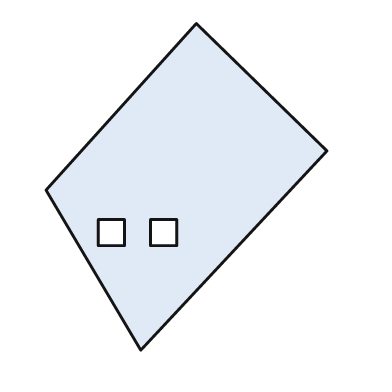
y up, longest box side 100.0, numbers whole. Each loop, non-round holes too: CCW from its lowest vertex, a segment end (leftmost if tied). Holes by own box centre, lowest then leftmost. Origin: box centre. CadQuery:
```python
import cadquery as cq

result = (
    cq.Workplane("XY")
    .moveTo(-14.0, -50.0)
    .lineTo(43.0, 11.0)
    .lineTo(3.0, 50.0)
    .lineTo(-43.0, -1.0)
    .close()
    .moveTo(-27.0, -18.0)
    .lineTo(-19.0, -18.0)
    .lineTo(-19.0, -10.0)
    .lineTo(-27.0, -10.0)
    .close()
    .moveTo(-11.0, -18.0)
    .lineTo(-3.0, -18.0)
    .lineTo(-3.0, -10.0)
    .lineTo(-11.0, -10.0)
    .close()
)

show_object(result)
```